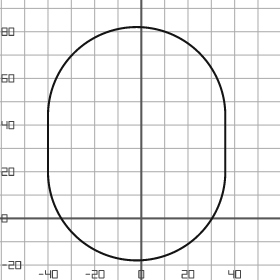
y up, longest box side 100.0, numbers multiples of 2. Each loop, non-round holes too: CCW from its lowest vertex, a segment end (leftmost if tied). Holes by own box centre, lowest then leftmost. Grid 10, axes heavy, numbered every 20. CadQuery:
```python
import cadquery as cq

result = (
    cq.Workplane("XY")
    .moveTo(-40.0, 20.0)
    .threePointArc((-2.0, -18.0), (36.0, 20.0))
    .lineTo(36.0, 44.0)
    .threePointArc((-2.0, 82.0), (-40.0, 44.0))
    .close()
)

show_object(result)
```